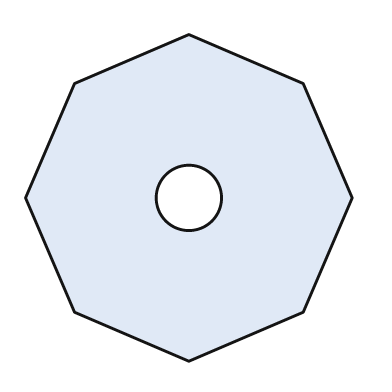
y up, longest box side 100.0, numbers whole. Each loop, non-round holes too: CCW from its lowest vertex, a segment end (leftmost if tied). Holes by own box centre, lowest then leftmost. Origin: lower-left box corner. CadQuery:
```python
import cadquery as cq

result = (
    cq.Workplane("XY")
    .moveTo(50.0, 0.0)
    .lineTo(85.0, 15.0)
    .lineTo(100.0, 50.0)
    .lineTo(85.0, 85.0)
    .lineTo(50.0, 100.0)
    .lineTo(15.0, 85.0)
    .lineTo(0.0, 50.0)
    .lineTo(15.0, 15.0)
    .close()
    .moveTo(50.0, 50.0)
    .circle(10.0)
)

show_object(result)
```